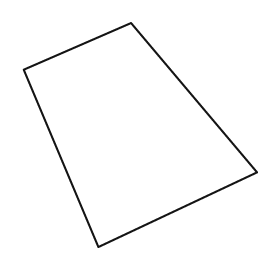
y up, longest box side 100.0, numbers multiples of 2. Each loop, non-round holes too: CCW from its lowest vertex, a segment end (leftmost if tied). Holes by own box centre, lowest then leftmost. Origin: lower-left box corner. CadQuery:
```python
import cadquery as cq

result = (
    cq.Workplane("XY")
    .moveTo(32.0, 0.0)
    .lineTo(100.0, 32.0)
    .lineTo(46.0, 96.0)
    .lineTo(0.0, 76.0)
    .close()
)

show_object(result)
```